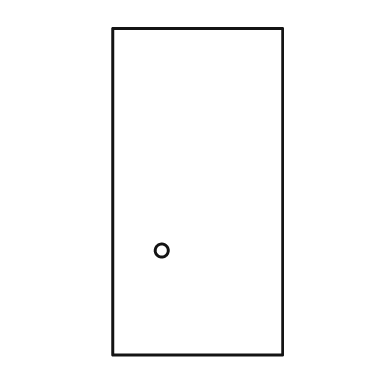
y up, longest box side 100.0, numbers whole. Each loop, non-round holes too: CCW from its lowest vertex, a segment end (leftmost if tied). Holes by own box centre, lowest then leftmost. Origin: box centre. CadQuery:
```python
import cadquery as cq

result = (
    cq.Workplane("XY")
    .moveTo(-26.0, -50.0)
    .lineTo(26.0, -50.0)
    .lineTo(26.0, 50.0)
    .lineTo(-26.0, 50.0)
    .close()
    .moveTo(-11.0, -18.0)
    .circle(2.0)
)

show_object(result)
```